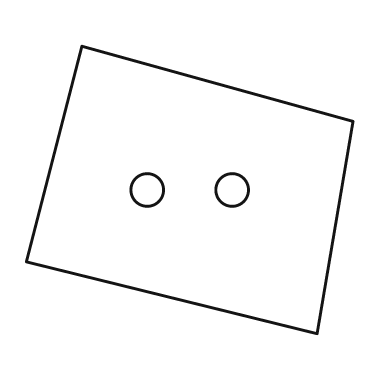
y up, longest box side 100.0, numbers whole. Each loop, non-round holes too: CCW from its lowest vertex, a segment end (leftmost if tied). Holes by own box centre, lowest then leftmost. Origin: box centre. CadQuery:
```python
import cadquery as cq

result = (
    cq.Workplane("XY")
    .moveTo(39.0, -44.0)
    .lineTo(50.0, 21.0)
    .lineTo(-33.0, 44.0)
    .lineTo(-50.0, -22.0)
    .close()
    .moveTo(-13.0, 0.0)
    .circle(5.0)
    .moveTo(13.0, 0.0)
    .circle(5.0)
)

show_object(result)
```